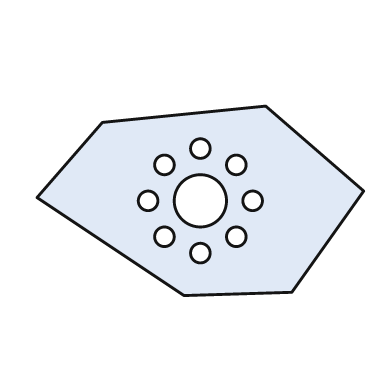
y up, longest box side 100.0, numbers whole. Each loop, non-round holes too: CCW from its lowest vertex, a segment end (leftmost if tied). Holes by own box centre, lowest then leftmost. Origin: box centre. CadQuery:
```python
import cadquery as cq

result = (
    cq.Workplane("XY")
    .moveTo(-5.0, -29.0)
    .lineTo(28.0, -28.0)
    .lineTo(50.0, 3.0)
    .lineTo(20.0, 29.0)
    .lineTo(-30.0, 24.0)
    .lineTo(-50.0, 1.0)
    .close()
    .moveTo(0.0, -16.0)
    .circle(3.0)
    .moveTo(-11.0, -11.0)
    .circle(3.0)
    .moveTo(11.0, -11.0)
    .circle(3.0)
    .moveTo(-16.0, 0.0)
    .circle(3.0)
    .moveTo(0.0, 0.0)
    .circle(8.0)
    .moveTo(16.0, 0.0)
    .circle(3.0)
    .moveTo(-11.0, 11.0)
    .circle(3.0)
    .moveTo(11.0, 11.0)
    .circle(3.0)
    .moveTo(0.0, 16.0)
    .circle(3.0)
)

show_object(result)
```